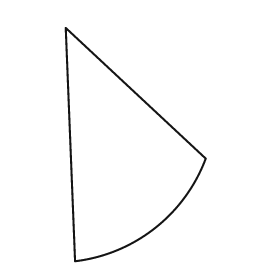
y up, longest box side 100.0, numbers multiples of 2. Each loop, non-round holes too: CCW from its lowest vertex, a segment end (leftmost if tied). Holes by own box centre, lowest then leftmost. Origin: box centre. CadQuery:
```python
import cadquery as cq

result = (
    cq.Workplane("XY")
    .moveTo(-26.0, -50.0)
    .threePointArc((8.0, -36.0), (30.0, -6.0))
    .lineTo(-30.0, 50.0)
    .close()
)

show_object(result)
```